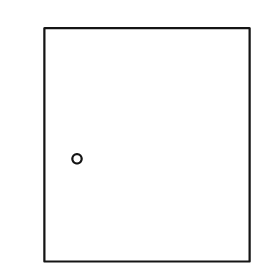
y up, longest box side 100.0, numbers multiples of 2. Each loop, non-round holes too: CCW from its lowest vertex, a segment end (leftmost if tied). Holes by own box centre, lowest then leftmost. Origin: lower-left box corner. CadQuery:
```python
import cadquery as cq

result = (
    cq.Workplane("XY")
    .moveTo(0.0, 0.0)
    .lineTo(88.0, 0.0)
    .lineTo(88.0, 100.0)
    .lineTo(0.0, 100.0)
    .close()
    .moveTo(14.0, 44.0)
    .circle(2.0)
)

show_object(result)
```